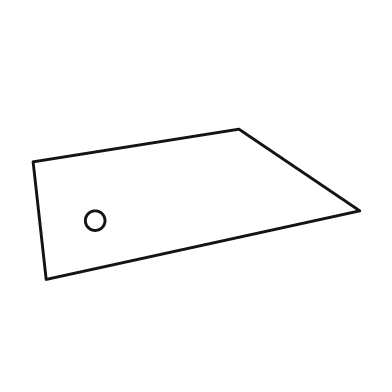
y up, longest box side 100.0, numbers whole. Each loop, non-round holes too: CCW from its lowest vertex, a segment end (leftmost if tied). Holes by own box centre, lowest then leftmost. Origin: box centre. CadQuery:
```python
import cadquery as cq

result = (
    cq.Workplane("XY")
    .moveTo(-46.0, -23.0)
    .lineTo(50.0, -2.0)
    .lineTo(13.0, 23.0)
    .lineTo(-50.0, 13.0)
    .close()
    .moveTo(-31.0, -5.0)
    .circle(3.0)
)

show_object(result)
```